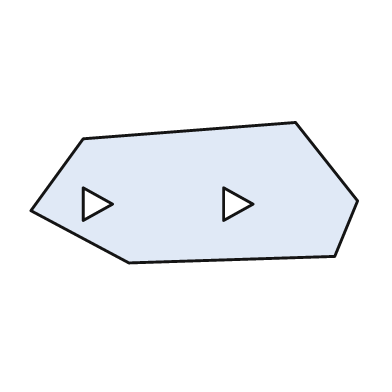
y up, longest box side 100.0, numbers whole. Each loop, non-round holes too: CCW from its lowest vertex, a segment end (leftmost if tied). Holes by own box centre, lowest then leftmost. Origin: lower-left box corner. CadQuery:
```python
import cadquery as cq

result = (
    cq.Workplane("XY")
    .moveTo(30.0, 0.0)
    .lineTo(93.0, 2.0)
    .lineTo(100.0, 19.0)
    .lineTo(81.0, 43.0)
    .lineTo(16.0, 38.0)
    .lineTo(0.0, 16.0)
    .close()
    .moveTo(16.0, 13.0)
    .lineTo(25.0, 18.0)
    .lineTo(16.0, 23.0)
    .close()
    .moveTo(59.0, 13.0)
    .lineTo(68.0, 18.0)
    .lineTo(59.0, 23.0)
    .close()
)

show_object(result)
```